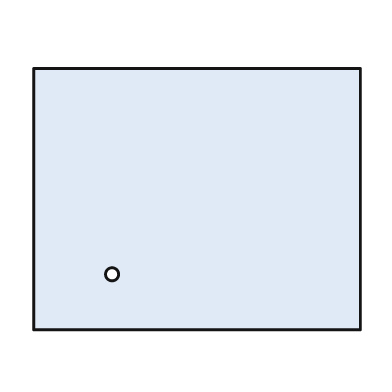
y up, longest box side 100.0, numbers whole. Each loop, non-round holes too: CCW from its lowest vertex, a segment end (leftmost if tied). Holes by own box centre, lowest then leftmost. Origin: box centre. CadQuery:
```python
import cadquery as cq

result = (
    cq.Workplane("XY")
    .moveTo(-50.0, -40.0)
    .lineTo(50.0, -40.0)
    .lineTo(50.0, 40.0)
    .lineTo(-50.0, 40.0)
    .close()
    .moveTo(-26.0, -23.0)
    .circle(2.0)
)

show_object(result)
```